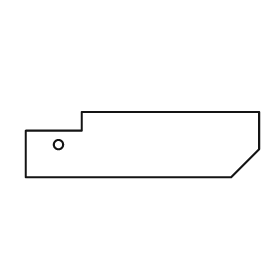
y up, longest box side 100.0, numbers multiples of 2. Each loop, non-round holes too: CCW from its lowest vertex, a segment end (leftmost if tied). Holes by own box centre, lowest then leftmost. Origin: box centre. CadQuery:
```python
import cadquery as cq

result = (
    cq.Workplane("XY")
    .moveTo(-50.0, -14.0)
    .lineTo(38.0, -14.0)
    .lineTo(50.0, -2.0)
    .lineTo(50.0, 14.0)
    .lineTo(-26.0, 14.0)
    .lineTo(-26.0, 6.0)
    .lineTo(-50.0, 6.0)
    .close()
    .moveTo(-36.0, 0.0)
    .circle(2.0)
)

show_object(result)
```